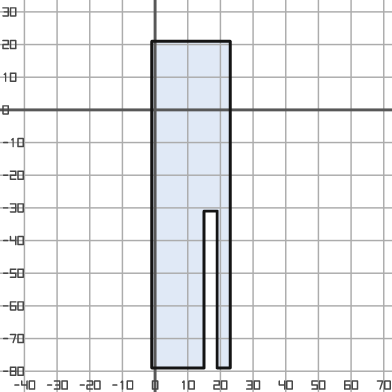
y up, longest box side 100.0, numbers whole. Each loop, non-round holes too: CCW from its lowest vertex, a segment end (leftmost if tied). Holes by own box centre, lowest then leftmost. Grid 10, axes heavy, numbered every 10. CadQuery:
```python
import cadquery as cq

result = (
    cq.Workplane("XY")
    .moveTo(-1.0, -79.0)
    .lineTo(15.0, -79.0)
    .lineTo(15.0, -31.0)
    .lineTo(19.0, -31.0)
    .lineTo(19.0, -79.0)
    .lineTo(23.0, -79.0)
    .lineTo(23.0, 21.0)
    .lineTo(-1.0, 21.0)
    .close()
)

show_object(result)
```